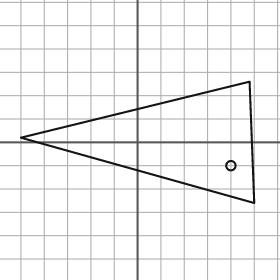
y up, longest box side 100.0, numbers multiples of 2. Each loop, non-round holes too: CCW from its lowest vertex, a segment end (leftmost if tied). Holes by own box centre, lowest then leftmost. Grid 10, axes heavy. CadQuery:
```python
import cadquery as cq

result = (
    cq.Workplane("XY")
    .moveTo(50.0, -26.0)
    .lineTo(48.0, 26.0)
    .lineTo(-50.0, 2.0)
    .close()
    .moveTo(40.0, -10.0)
    .circle(2.0)
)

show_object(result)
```